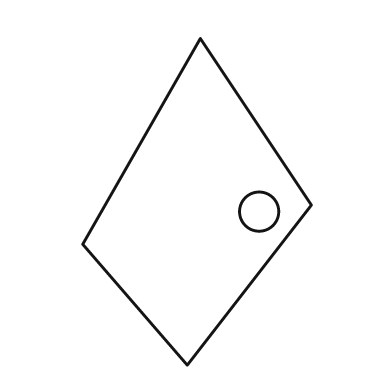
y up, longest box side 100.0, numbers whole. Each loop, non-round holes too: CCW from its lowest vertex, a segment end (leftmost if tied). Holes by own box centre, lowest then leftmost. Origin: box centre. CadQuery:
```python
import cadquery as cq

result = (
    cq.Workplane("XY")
    .moveTo(-3.0, -50.0)
    .lineTo(35.0, -1.0)
    .lineTo(1.0, 50.0)
    .lineTo(-35.0, -13.0)
    .close()
    .moveTo(19.0, -3.0)
    .circle(6.0)
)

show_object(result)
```